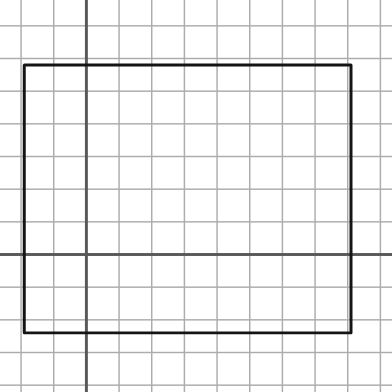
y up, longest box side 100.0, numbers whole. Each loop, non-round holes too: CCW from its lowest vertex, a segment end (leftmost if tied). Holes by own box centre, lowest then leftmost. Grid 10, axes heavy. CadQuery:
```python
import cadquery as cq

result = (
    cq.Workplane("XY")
    .moveTo(-19.0, -24.0)
    .lineTo(81.0, -24.0)
    .lineTo(81.0, 58.0)
    .lineTo(-19.0, 58.0)
    .close()
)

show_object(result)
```